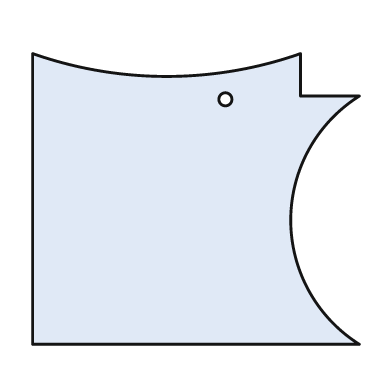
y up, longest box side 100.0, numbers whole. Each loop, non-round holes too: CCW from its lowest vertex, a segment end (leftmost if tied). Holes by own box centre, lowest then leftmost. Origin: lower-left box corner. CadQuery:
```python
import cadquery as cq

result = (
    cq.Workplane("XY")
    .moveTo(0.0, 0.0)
    .lineTo(100.0, 0.0)
    .threePointArc((79.0, 38.0), (100.0, 76.0))
    .lineTo(82.0, 76.0)
    .lineTo(82.0, 89.0)
    .threePointArc((41.0, 82.0), (0.0, 89.0))
    .close()
    .moveTo(59.0, 75.0)
    .circle(2.0)
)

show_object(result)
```